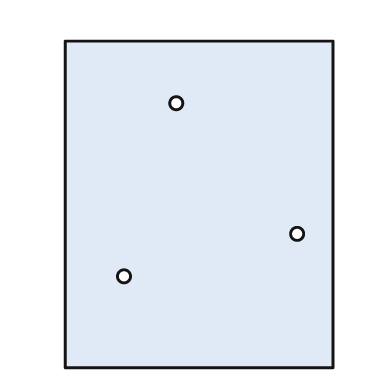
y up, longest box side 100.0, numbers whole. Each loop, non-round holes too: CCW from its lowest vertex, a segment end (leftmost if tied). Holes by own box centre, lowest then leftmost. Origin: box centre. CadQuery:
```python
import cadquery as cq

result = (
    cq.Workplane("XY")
    .moveTo(-41.0, -50.0)
    .lineTo(41.0, -50.0)
    .lineTo(41.0, 50.0)
    .lineTo(-41.0, 50.0)
    .close()
    .moveTo(-23.0, -22.0)
    .circle(2.0)
    .moveTo(30.0, -9.0)
    .circle(2.0)
    .moveTo(-7.0, 31.0)
    .circle(2.0)
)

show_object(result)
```